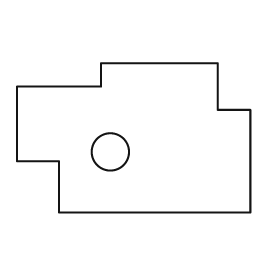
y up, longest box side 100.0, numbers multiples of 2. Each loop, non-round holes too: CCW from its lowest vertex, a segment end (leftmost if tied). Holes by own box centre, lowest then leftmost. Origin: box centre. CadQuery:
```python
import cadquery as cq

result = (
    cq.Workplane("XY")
    .moveTo(-32.0, -32.0)
    .lineTo(50.0, -32.0)
    .lineTo(50.0, 12.0)
    .lineTo(36.0, 12.0)
    .lineTo(36.0, 32.0)
    .lineTo(-14.0, 32.0)
    .lineTo(-14.0, 22.0)
    .lineTo(-50.0, 22.0)
    .lineTo(-50.0, -10.0)
    .lineTo(-32.0, -10.0)
    .close()
    .moveTo(-10.0, -6.0)
    .circle(8.0)
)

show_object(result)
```